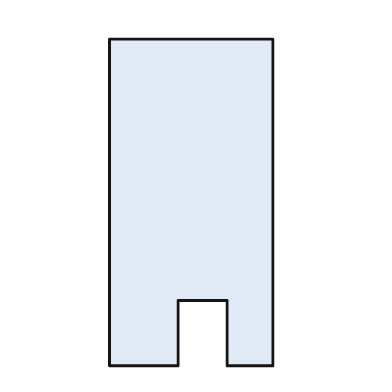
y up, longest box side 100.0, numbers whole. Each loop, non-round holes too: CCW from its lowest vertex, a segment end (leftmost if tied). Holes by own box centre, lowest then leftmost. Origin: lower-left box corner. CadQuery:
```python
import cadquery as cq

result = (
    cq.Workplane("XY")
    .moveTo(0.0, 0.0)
    .lineTo(21.0, 0.0)
    .lineTo(21.0, 20.0)
    .lineTo(36.0, 20.0)
    .lineTo(36.0, 0.0)
    .lineTo(50.0, 0.0)
    .lineTo(50.0, 100.0)
    .lineTo(0.0, 100.0)
    .close()
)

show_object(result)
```